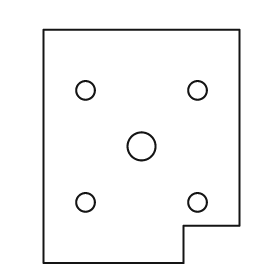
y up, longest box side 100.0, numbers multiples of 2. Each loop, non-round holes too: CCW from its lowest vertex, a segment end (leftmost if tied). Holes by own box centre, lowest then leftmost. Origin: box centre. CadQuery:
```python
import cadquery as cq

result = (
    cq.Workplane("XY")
    .moveTo(-42.0, -50.0)
    .lineTo(18.0, -50.0)
    .lineTo(18.0, -34.0)
    .lineTo(42.0, -34.0)
    .lineTo(42.0, 50.0)
    .lineTo(-42.0, 50.0)
    .close()
    .moveTo(-24.0, -24.0)
    .circle(4.0)
    .moveTo(24.0, -24.0)
    .circle(4.0)
    .moveTo(0.0, 0.0)
    .circle(6.0)
    .moveTo(-24.0, 24.0)
    .circle(4.0)
    .moveTo(24.0, 24.0)
    .circle(4.0)
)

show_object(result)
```